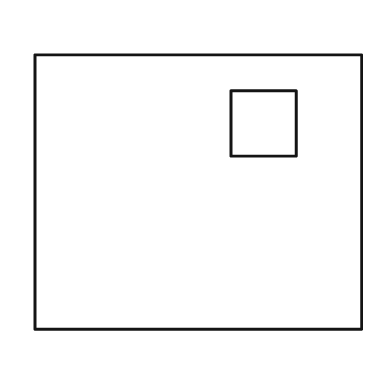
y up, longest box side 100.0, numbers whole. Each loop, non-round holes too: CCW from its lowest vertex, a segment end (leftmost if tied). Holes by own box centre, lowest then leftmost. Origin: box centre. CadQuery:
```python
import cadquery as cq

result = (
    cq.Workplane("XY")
    .moveTo(-50.0, -42.0)
    .lineTo(50.0, -42.0)
    .lineTo(50.0, 42.0)
    .lineTo(-50.0, 42.0)
    .close()
    .moveTo(10.0, 11.0)
    .lineTo(30.0, 11.0)
    .lineTo(30.0, 31.0)
    .lineTo(10.0, 31.0)
    .close()
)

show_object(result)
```